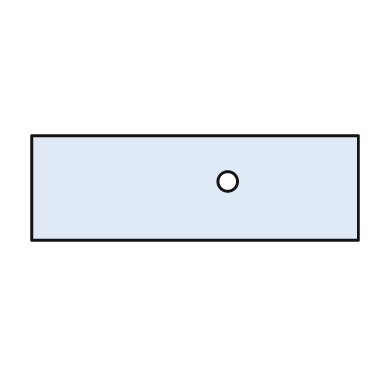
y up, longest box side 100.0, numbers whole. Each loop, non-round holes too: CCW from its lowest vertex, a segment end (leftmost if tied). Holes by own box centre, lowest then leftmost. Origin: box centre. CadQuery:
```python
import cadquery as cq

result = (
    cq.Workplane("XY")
    .moveTo(-50.0, -16.0)
    .lineTo(50.0, -16.0)
    .lineTo(50.0, 16.0)
    .lineTo(-50.0, 16.0)
    .close()
    .moveTo(10.0, 2.0)
    .circle(3.0)
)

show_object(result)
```